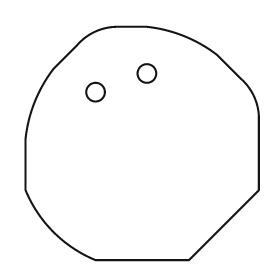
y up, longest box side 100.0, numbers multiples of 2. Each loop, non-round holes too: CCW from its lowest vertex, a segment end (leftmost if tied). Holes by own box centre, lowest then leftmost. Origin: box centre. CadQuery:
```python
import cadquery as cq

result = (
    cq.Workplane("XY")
    .moveTo(-20.0, -50.0)
    .lineTo(20.0, -50.0)
    .lineTo(50.0, -20.0)
    .lineTo(50.0, 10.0)
    .threePointArc((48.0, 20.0), (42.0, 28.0))
    .lineTo(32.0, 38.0)
    .threePointArc((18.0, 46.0), (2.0, 50.0))
    .lineTo(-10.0, 50.0)
    .threePointArc((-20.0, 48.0), (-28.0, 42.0))
    .lineTo(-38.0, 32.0)
    .threePointArc((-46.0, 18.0), (-50.0, 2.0))
    .lineTo(-50.0, -20.0)
    .threePointArc((-38.0, -38.0), (-20.0, -50.0))
    .close()
    .moveTo(-20.0, 22.0)
    .circle(4.0)
    .moveTo(2.0, 30.0)
    .circle(4.0)
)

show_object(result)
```